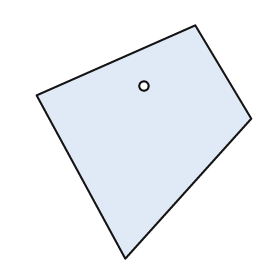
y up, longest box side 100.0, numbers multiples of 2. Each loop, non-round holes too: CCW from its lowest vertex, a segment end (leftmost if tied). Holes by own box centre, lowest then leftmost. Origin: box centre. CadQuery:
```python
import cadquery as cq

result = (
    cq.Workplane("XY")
    .moveTo(-8.0, -50.0)
    .lineTo(46.0, 10.0)
    .lineTo(22.0, 50.0)
    .lineTo(-46.0, 20.0)
    .close()
    .moveTo(0.0, 24.0)
    .circle(2.0)
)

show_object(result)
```